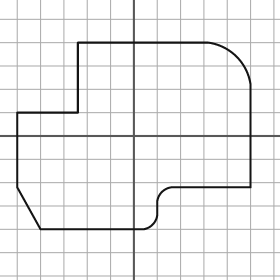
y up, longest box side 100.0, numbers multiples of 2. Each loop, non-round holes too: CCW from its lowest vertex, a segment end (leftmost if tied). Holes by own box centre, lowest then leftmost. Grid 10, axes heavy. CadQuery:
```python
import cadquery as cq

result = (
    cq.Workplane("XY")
    .moveTo(-40.0, -40.0)
    .lineTo(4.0, -40.0)
    .threePointArc((8.0, -38.0), (10.0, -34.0))
    .lineTo(10.0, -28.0)
    .threePointArc((12.0, -24.0), (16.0, -22.0))
    .lineTo(50.0, -22.0)
    .lineTo(50.0, 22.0)
    .threePointArc((44.0, 34.0), (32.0, 40.0))
    .lineTo(-24.0, 40.0)
    .lineTo(-24.0, 10.0)
    .lineTo(-50.0, 10.0)
    .lineTo(-50.0, -22.0)
    .close()
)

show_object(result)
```